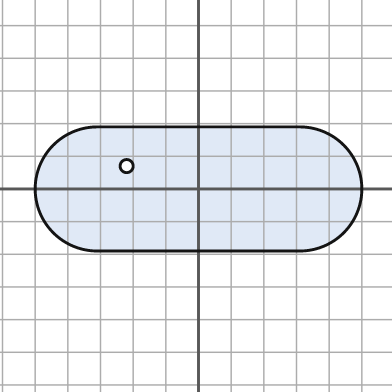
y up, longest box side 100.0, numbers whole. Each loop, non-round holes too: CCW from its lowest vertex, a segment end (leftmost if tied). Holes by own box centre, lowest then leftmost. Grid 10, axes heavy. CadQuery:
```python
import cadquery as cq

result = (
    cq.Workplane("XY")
    .moveTo(-31.0, -19.0)
    .lineTo(31.0, -19.0)
    .threePointArc((50.0, 0.0), (31.0, 19.0))
    .lineTo(-31.0, 19.0)
    .threePointArc((-50.0, 0.0), (-31.0, -19.0))
    .close()
    .moveTo(-22.0, 7.0)
    .circle(2.0)
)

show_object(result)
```